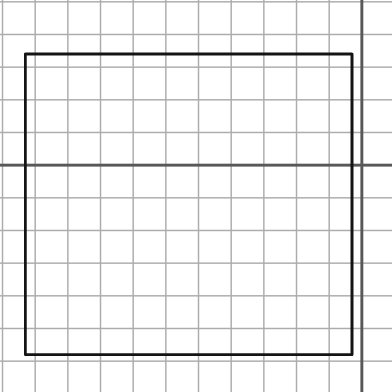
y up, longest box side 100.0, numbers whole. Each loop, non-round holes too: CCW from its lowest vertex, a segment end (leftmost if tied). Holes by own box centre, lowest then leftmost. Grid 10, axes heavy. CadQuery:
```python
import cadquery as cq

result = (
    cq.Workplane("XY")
    .moveTo(-103.0, -58.0)
    .lineTo(-3.0, -58.0)
    .lineTo(-3.0, 34.0)
    .lineTo(-103.0, 34.0)
    .close()
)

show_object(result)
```